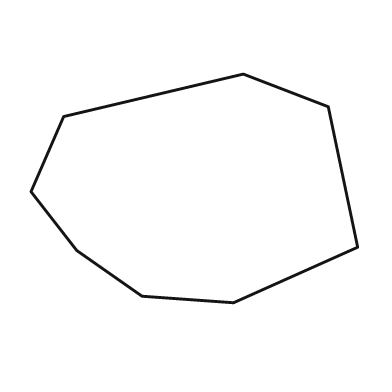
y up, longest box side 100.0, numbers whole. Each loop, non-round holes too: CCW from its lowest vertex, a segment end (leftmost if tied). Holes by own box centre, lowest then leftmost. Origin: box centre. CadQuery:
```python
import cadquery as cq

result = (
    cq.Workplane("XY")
    .moveTo(12.0, -35.0)
    .lineTo(50.0, -18.0)
    .lineTo(41.0, 25.0)
    .lineTo(15.0, 35.0)
    .lineTo(-40.0, 22.0)
    .lineTo(-50.0, -1.0)
    .lineTo(-36.0, -19.0)
    .lineTo(-16.0, -33.0)
    .close()
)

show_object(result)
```